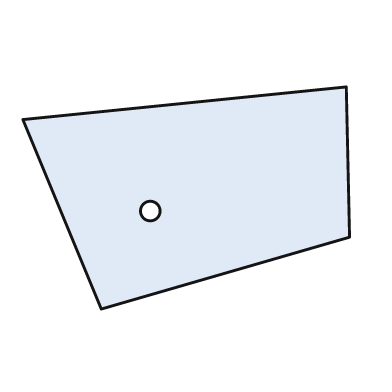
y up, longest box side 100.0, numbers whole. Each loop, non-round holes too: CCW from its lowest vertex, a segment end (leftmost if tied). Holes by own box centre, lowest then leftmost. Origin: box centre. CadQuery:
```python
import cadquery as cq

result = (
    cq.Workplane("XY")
    .moveTo(-26.0, -34.0)
    .lineTo(50.0, -12.0)
    .lineTo(49.0, 34.0)
    .lineTo(-50.0, 24.0)
    .close()
    .moveTo(-11.0, -4.0)
    .circle(3.0)
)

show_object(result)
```